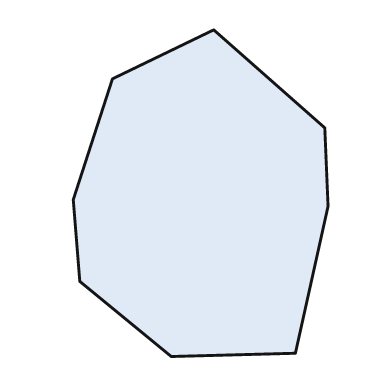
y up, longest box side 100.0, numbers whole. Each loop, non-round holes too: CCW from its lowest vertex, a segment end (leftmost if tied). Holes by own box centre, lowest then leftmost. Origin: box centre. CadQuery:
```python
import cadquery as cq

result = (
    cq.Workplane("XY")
    .moveTo(-9.0, -50.0)
    .lineTo(29.0, -49.0)
    .lineTo(39.0, -4.0)
    .lineTo(38.0, 20.0)
    .lineTo(4.0, 50.0)
    .lineTo(-27.0, 35.0)
    .lineTo(-39.0, -2.0)
    .lineTo(-37.0, -27.0)
    .close()
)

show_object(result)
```